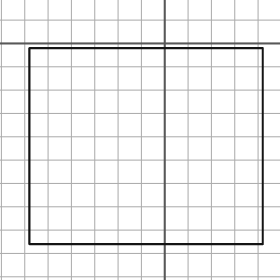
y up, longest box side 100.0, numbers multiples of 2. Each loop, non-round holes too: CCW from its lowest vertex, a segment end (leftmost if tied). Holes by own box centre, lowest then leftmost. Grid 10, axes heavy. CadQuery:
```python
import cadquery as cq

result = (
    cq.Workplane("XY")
    .moveTo(-58.0, -86.0)
    .lineTo(42.0, -86.0)
    .lineTo(42.0, -2.0)
    .lineTo(-58.0, -2.0)
    .close()
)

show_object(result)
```